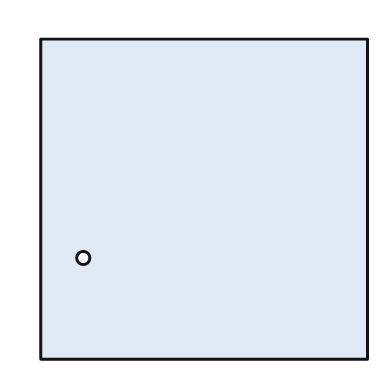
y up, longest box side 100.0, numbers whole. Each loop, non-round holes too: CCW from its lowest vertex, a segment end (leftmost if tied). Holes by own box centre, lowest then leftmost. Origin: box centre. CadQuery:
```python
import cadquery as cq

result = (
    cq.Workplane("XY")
    .moveTo(-50.0, -49.0)
    .lineTo(50.0, -49.0)
    .lineTo(50.0, 49.0)
    .lineTo(-50.0, 49.0)
    .close()
    .moveTo(-37.0, -18.0)
    .circle(2.0)
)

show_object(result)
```